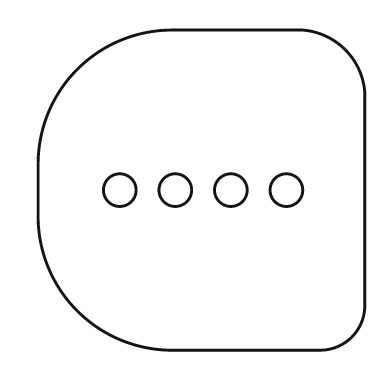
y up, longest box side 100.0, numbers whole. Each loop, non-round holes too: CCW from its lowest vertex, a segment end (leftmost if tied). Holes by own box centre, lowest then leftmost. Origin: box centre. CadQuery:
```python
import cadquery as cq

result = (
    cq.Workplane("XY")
    .moveTo(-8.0, -49.0)
    .lineTo(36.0, -49.0)
    .threePointArc((46.0, -45.0), (50.0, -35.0))
    .lineTo(50.0, 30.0)
    .threePointArc((44.0, 43.0), (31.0, 49.0))
    .lineTo(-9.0, 49.0)
    .threePointArc((-38.0, 37.0), (-50.0, 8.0))
    .lineTo(-50.0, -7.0)
    .threePointArc((-38.0, -37.0), (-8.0, -49.0))
    .close()
    .moveTo(-25.0, 0.0)
    .circle(5.0)
    .moveTo(-8.0, 0.0)
    .circle(5.0)
    .moveTo(9.0, 0.0)
    .circle(5.0)
    .moveTo(26.0, 0.0)
    .circle(5.0)
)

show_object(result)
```